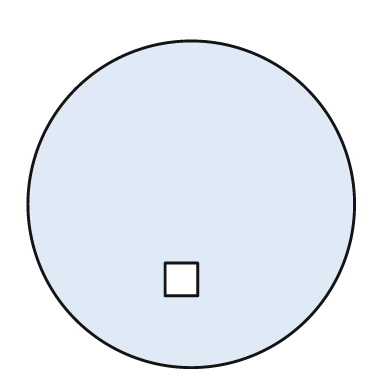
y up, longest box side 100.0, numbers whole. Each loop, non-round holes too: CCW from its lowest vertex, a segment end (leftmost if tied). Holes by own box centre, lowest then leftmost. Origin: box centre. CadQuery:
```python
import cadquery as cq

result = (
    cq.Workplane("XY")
    .moveTo(0.0, 0.0)
    .circle(50.0)
    .moveTo(-8.0, -28.0)
    .lineTo(2.0, -28.0)
    .lineTo(2.0, -18.0)
    .lineTo(-8.0, -18.0)
    .close()
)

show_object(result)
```